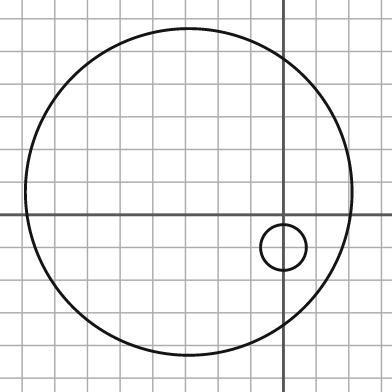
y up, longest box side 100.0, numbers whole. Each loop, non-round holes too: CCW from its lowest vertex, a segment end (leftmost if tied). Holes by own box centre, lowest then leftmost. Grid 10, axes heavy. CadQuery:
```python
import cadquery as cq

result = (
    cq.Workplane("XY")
    .moveTo(-29.0, 7.0)
    .circle(50.0)
    .moveTo(0.0, -10.0)
    .circle(7.0)
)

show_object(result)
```